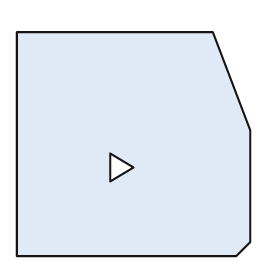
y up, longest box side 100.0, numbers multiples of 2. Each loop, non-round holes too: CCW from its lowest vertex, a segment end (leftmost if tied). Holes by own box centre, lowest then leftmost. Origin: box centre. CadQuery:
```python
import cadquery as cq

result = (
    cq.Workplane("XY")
    .moveTo(-50.0, -48.0)
    .lineTo(44.0, -48.0)
    .lineTo(50.0, -42.0)
    .lineTo(50.0, 6.0)
    .lineTo(34.0, 48.0)
    .lineTo(-50.0, 48.0)
    .close()
    .moveTo(-10.0, -16.0)
    .lineTo(0.0, -10.0)
    .lineTo(-10.0, -4.0)
    .close()
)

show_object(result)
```